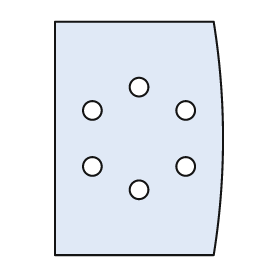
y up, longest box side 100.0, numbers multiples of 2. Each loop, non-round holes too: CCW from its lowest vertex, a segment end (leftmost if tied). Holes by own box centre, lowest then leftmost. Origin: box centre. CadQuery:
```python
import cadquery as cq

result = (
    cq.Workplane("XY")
    .moveTo(-36.0, -50.0)
    .lineTo(32.0, -50.0)
    .threePointArc((36.0, 0.0), (32.0, 50.0))
    .lineTo(-36.0, 50.0)
    .close()
    .moveTo(0.0, -22.0)
    .circle(4.0)
    .moveTo(-20.0, -12.0)
    .circle(4.0)
    .moveTo(20.0, -12.0)
    .circle(4.0)
    .moveTo(-20.0, 12.0)
    .circle(4.0)
    .moveTo(20.0, 12.0)
    .circle(4.0)
    .moveTo(0.0, 22.0)
    .circle(4.0)
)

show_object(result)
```